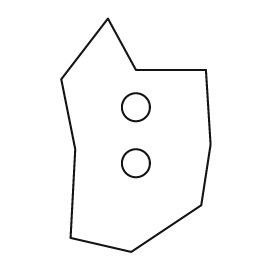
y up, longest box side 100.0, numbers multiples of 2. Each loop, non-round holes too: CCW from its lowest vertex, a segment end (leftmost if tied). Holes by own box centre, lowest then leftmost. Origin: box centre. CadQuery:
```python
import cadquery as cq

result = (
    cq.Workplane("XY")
    .moveTo(-2.0, -50.0)
    .lineTo(28.0, -30.0)
    .lineTo(32.0, -4.0)
    .lineTo(30.0, 28.0)
    .lineTo(0.0, 28.0)
    .lineTo(-12.0, 50.0)
    .lineTo(-32.0, 24.0)
    .lineTo(-26.0, -6.0)
    .lineTo(-28.0, -44.0)
    .close()
    .moveTo(0.0, -12.0)
    .circle(6.0)
    .moveTo(0.0, 12.0)
    .circle(6.0)
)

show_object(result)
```